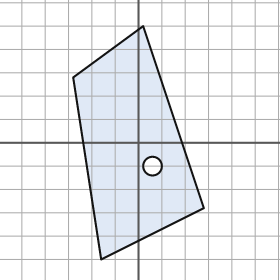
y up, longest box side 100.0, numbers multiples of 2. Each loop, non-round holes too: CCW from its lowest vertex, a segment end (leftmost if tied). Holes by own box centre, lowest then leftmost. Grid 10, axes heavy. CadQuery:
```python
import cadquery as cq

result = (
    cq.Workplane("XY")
    .moveTo(-16.0, -50.0)
    .lineTo(28.0, -28.0)
    .lineTo(2.0, 50.0)
    .lineTo(-28.0, 28.0)
    .close()
    .moveTo(6.0, -10.0)
    .circle(4.0)
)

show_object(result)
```